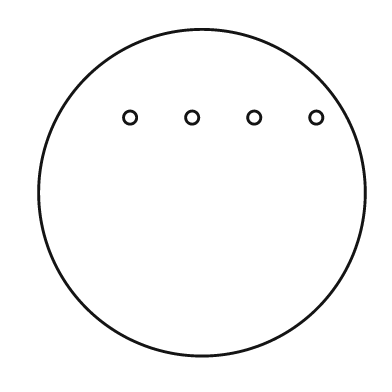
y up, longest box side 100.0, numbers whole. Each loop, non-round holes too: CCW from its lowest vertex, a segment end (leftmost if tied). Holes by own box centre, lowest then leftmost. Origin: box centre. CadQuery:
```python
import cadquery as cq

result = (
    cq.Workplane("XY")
    .moveTo(0.0, 0.0)
    .circle(50.0)
    .moveTo(-22.0, 23.0)
    .circle(2.0)
    .moveTo(-3.0, 23.0)
    .circle(2.0)
    .moveTo(16.0, 23.0)
    .circle(2.0)
    .moveTo(35.0, 23.0)
    .circle(2.0)
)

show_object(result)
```